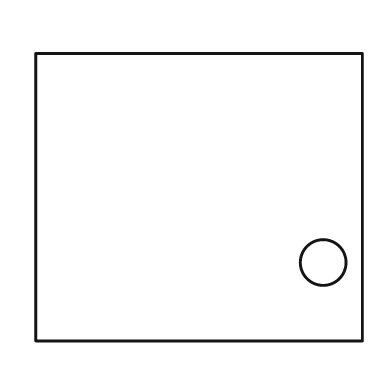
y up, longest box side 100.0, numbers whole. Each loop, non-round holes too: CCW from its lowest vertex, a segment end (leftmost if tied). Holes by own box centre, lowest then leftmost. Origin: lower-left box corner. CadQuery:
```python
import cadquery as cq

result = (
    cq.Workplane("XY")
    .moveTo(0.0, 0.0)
    .lineTo(100.0, 0.0)
    .lineTo(100.0, 88.0)
    .lineTo(0.0, 88.0)
    .close()
    .moveTo(88.0, 24.0)
    .circle(7.0)
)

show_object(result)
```